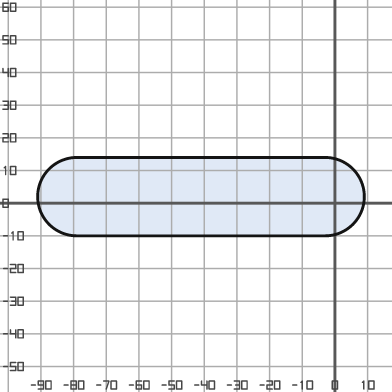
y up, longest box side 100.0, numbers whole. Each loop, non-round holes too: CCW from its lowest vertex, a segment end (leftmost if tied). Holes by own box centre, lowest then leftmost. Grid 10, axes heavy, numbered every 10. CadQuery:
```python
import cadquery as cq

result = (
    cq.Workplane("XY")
    .moveTo(-79.0, -10.0)
    .lineTo(-3.0, -10.0)
    .threePointArc((9.0, 2.0), (-3.0, 14.0))
    .lineTo(-79.0, 14.0)
    .threePointArc((-91.0, 2.0), (-79.0, -10.0))
    .close()
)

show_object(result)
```